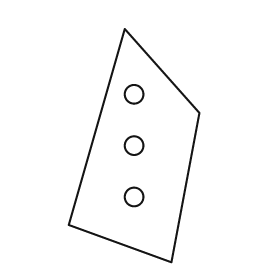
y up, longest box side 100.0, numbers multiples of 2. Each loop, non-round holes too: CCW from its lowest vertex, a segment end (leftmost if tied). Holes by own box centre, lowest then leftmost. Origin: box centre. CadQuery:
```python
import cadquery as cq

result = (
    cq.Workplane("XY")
    .moveTo(16.0, -50.0)
    .lineTo(28.0, 14.0)
    .lineTo(-4.0, 50.0)
    .lineTo(-28.0, -34.0)
    .close()
    .moveTo(0.0, -22.0)
    .circle(4.0)
    .moveTo(0.0, 0.0)
    .circle(4.0)
    .moveTo(0.0, 22.0)
    .circle(4.0)
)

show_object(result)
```